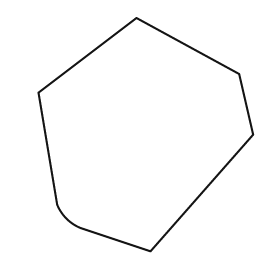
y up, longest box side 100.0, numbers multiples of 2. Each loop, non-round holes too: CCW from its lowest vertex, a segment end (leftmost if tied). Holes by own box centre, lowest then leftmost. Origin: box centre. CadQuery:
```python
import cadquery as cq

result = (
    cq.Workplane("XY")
    .moveTo(2.0, -50.0)
    .lineTo(46.0, 0.0)
    .lineTo(40.0, 26.0)
    .lineTo(-4.0, 50.0)
    .lineTo(-46.0, 18.0)
    .lineTo(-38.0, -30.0)
    .threePointArc((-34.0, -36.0), (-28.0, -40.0))
    .close()
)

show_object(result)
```